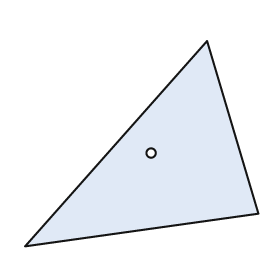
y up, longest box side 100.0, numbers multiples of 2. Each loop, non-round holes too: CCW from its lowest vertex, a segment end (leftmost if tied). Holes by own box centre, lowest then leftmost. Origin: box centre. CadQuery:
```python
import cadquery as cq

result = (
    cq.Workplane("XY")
    .moveTo(-50.0, -44.0)
    .lineTo(50.0, -30.0)
    .lineTo(28.0, 44.0)
    .close()
    .moveTo(4.0, -4.0)
    .circle(2.0)
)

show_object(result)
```